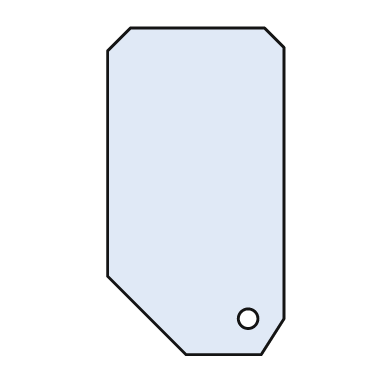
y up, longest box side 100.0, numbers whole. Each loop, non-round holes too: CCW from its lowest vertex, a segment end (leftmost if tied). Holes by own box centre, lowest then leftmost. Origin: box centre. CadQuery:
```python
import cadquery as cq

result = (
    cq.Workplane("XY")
    .moveTo(-3.0, -50.0)
    .lineTo(20.0, -50.0)
    .lineTo(27.0, -39.0)
    .lineTo(27.0, 44.0)
    .lineTo(21.0, 50.0)
    .lineTo(-20.0, 50.0)
    .lineTo(-27.0, 43.0)
    .lineTo(-27.0, -26.0)
    .close()
    .moveTo(16.0, -39.0)
    .circle(3.0)
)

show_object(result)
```